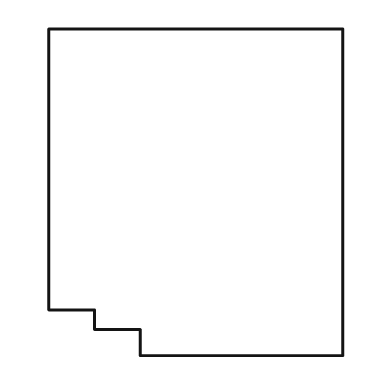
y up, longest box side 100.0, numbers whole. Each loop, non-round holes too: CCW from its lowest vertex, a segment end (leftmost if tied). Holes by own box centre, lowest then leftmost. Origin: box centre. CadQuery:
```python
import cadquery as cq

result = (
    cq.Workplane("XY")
    .moveTo(-17.0, -50.0)
    .lineTo(45.0, -50.0)
    .lineTo(45.0, 50.0)
    .lineTo(-45.0, 50.0)
    .lineTo(-45.0, -36.0)
    .lineTo(-31.0, -36.0)
    .lineTo(-31.0, -42.0)
    .lineTo(-17.0, -42.0)
    .close()
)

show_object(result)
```